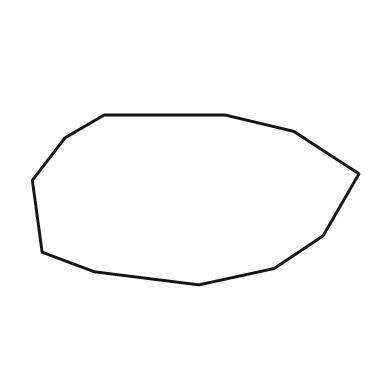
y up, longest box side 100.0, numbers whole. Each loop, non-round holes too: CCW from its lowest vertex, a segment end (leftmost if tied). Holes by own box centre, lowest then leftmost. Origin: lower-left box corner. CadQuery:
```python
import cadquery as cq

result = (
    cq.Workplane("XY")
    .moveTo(51.0, 0.0)
    .lineTo(74.0, 5.0)
    .lineTo(89.0, 15.0)
    .lineTo(100.0, 34.0)
    .lineTo(80.0, 47.0)
    .lineTo(59.0, 52.0)
    .lineTo(22.0, 52.0)
    .lineTo(10.0, 45.0)
    .lineTo(0.0, 32.0)
    .lineTo(3.0, 10.0)
    .lineTo(19.0, 4.0)
    .close()
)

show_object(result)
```